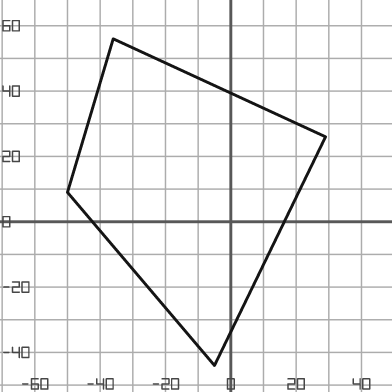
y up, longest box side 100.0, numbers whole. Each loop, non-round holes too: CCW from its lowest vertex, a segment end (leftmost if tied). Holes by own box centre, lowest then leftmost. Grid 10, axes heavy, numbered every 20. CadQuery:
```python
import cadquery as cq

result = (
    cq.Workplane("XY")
    .moveTo(-5.0, -44.0)
    .lineTo(29.0, 26.0)
    .lineTo(-36.0, 56.0)
    .lineTo(-50.0, 9.0)
    .close()
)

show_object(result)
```